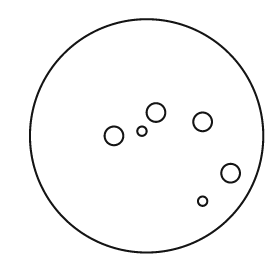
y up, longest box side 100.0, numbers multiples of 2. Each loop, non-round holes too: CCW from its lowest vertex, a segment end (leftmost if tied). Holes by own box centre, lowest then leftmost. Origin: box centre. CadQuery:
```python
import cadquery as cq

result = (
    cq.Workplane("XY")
    .moveTo(0.0, 0.0)
    .circle(50.0)
    .moveTo(24.0, -28.0)
    .circle(2.0)
    .moveTo(36.0, -16.0)
    .circle(4.0)
    .moveTo(-14.0, 0.0)
    .circle(4.0)
    .moveTo(-2.0, 2.0)
    .circle(2.0)
    .moveTo(24.0, 6.0)
    .circle(4.0)
    .moveTo(4.0, 10.0)
    .circle(4.0)
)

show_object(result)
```